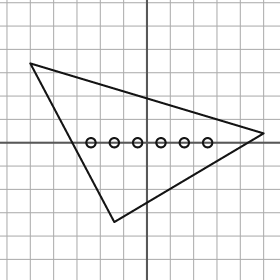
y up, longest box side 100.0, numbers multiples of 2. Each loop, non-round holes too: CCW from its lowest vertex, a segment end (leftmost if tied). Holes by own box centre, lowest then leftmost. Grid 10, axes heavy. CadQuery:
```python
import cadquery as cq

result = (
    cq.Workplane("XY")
    .moveTo(-14.0, -34.0)
    .lineTo(50.0, 4.0)
    .lineTo(-50.0, 34.0)
    .close()
    .moveTo(-24.0, 0.0)
    .circle(2.0)
    .moveTo(-14.0, 0.0)
    .circle(2.0)
    .moveTo(-4.0, 0.0)
    .circle(2.0)
    .moveTo(6.0, 0.0)
    .circle(2.0)
    .moveTo(16.0, 0.0)
    .circle(2.0)
    .moveTo(26.0, 0.0)
    .circle(2.0)
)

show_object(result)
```